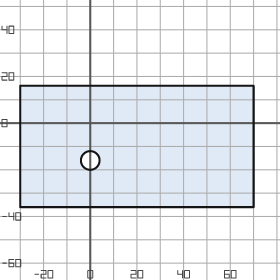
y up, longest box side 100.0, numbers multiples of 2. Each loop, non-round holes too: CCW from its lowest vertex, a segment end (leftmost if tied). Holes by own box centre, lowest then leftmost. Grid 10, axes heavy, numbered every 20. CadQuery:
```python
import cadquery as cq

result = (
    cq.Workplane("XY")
    .moveTo(-30.0, -36.0)
    .lineTo(70.0, -36.0)
    .lineTo(70.0, 16.0)
    .lineTo(-30.0, 16.0)
    .close()
    .moveTo(0.0, -16.0)
    .circle(4.0)
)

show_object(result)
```